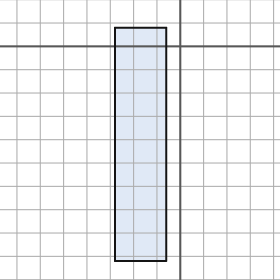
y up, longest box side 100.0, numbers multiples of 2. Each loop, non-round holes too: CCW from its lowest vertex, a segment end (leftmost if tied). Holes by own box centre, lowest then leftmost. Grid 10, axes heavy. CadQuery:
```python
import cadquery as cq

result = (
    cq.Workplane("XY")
    .moveTo(-28.0, -92.0)
    .lineTo(-6.0, -92.0)
    .lineTo(-6.0, 8.0)
    .lineTo(-28.0, 8.0)
    .close()
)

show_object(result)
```